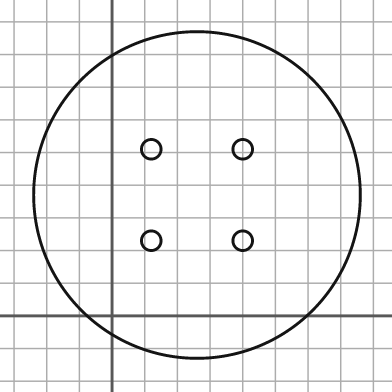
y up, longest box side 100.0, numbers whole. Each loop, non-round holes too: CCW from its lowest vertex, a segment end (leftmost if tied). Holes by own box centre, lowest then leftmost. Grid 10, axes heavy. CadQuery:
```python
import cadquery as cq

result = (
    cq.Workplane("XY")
    .moveTo(26.0, 37.0)
    .circle(50.0)
    .moveTo(12.0, 23.0)
    .circle(3.0)
    .moveTo(40.0, 23.0)
    .circle(3.0)
    .moveTo(12.0, 51.0)
    .circle(3.0)
    .moveTo(40.0, 51.0)
    .circle(3.0)
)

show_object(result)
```